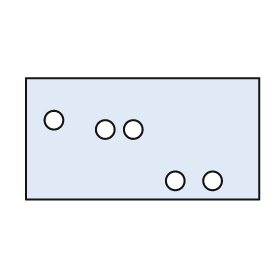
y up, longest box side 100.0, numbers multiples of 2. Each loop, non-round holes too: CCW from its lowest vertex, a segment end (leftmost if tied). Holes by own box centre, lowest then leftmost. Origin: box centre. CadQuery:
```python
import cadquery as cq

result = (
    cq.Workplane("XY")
    .moveTo(-50.0, -26.0)
    .lineTo(50.0, -26.0)
    .lineTo(50.0, 26.0)
    .lineTo(-50.0, 26.0)
    .close()
    .moveTo(14.0, -18.0)
    .circle(4.0)
    .moveTo(30.0, -18.0)
    .circle(4.0)
    .moveTo(-16.0, 4.0)
    .circle(4.0)
    .moveTo(-4.0, 4.0)
    .circle(4.0)
    .moveTo(-38.0, 8.0)
    .circle(4.0)
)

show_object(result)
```